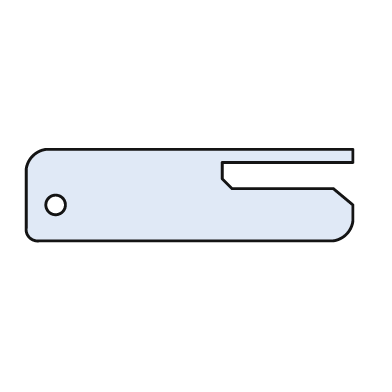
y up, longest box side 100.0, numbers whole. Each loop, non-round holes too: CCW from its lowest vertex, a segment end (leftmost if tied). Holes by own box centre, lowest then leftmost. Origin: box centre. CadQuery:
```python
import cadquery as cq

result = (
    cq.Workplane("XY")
    .moveTo(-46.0, -14.0)
    .lineTo(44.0, -14.0)
    .threePointArc((48.0, -12.0), (50.0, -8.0))
    .lineTo(50.0, -3.0)
    .lineTo(44.0, 2.0)
    .lineTo(13.0, 2.0)
    .lineTo(10.0, 5.0)
    .lineTo(10.0, 10.0)
    .lineTo(50.0, 10.0)
    .lineTo(50.0, 14.0)
    .lineTo(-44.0, 14.0)
    .threePointArc((-48.0, 12.0), (-50.0, 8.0))
    .lineTo(-50.0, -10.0)
    .threePointArc((-49.0, -13.0), (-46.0, -14.0))
    .close()
    .moveTo(-41.0, -3.0)
    .circle(3.0)
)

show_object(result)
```